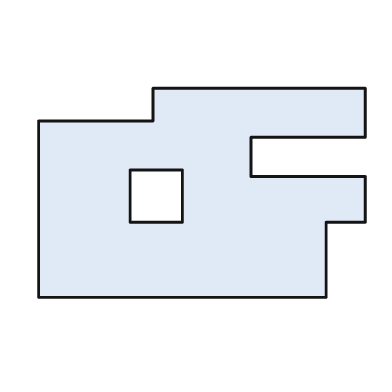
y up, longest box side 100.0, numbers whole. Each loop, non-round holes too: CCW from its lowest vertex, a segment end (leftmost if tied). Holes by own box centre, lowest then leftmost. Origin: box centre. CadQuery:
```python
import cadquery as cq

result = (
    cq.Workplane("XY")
    .moveTo(-50.0, -32.0)
    .lineTo(38.0, -32.0)
    .lineTo(38.0, -9.0)
    .lineTo(50.0, -9.0)
    .lineTo(50.0, 5.0)
    .lineTo(15.0, 5.0)
    .lineTo(15.0, 17.0)
    .lineTo(50.0, 17.0)
    .lineTo(50.0, 32.0)
    .lineTo(-15.0, 32.0)
    .lineTo(-15.0, 22.0)
    .lineTo(-50.0, 22.0)
    .close()
    .moveTo(-22.0, -9.0)
    .lineTo(-6.0, -9.0)
    .lineTo(-6.0, 7.0)
    .lineTo(-22.0, 7.0)
    .close()
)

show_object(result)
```